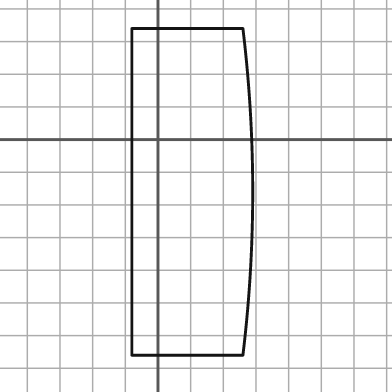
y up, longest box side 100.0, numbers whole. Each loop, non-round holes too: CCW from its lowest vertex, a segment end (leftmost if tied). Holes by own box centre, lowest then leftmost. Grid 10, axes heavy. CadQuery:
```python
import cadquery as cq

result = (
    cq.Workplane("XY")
    .moveTo(-8.0, -66.0)
    .lineTo(26.0, -66.0)
    .threePointArc((29.0, -16.0), (26.0, 34.0))
    .lineTo(-8.0, 34.0)
    .close()
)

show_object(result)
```